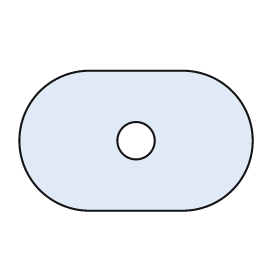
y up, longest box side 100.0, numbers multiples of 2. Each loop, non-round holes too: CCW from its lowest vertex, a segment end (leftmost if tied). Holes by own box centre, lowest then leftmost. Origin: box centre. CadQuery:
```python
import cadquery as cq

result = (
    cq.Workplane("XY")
    .moveTo(-20.0, -30.0)
    .lineTo(20.0, -30.0)
    .threePointArc((50.0, 0.0), (20.0, 30.0))
    .lineTo(-20.0, 30.0)
    .threePointArc((-50.0, 0.0), (-20.0, -30.0))
    .close()
    .moveTo(0.0, 0.0)
    .circle(8.0)
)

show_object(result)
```